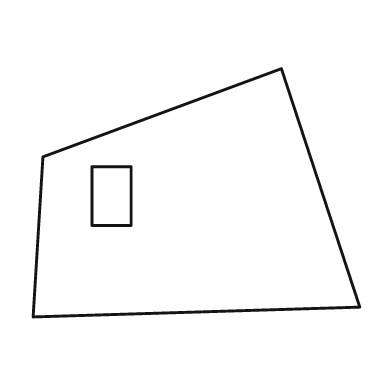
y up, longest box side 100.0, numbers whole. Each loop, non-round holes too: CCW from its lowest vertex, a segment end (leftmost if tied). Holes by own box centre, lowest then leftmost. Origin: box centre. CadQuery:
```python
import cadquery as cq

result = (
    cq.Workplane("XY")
    .moveTo(-50.0, -38.0)
    .lineTo(50.0, -35.0)
    .lineTo(26.0, 38.0)
    .lineTo(-47.0, 11.0)
    .close()
    .moveTo(-32.0, -10.0)
    .lineTo(-20.0, -10.0)
    .lineTo(-20.0, 8.0)
    .lineTo(-32.0, 8.0)
    .close()
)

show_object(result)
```